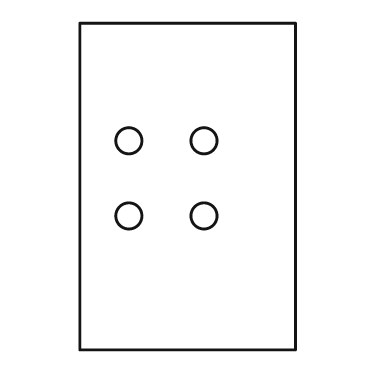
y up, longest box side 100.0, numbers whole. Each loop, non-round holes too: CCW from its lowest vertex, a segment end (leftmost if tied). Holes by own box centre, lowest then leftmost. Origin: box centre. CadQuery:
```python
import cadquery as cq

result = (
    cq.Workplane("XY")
    .moveTo(-33.0, -50.0)
    .lineTo(33.0, -50.0)
    .lineTo(33.0, 50.0)
    .lineTo(-33.0, 50.0)
    .close()
    .moveTo(-18.0, -9.0)
    .circle(4.0)
    .moveTo(5.0, -9.0)
    .circle(4.0)
    .moveTo(-18.0, 14.0)
    .circle(4.0)
    .moveTo(5.0, 14.0)
    .circle(4.0)
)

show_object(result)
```